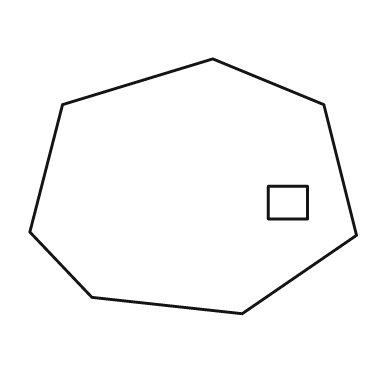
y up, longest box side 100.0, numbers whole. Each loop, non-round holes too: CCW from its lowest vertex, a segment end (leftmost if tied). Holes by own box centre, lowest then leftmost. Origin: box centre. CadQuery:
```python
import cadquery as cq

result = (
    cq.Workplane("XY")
    .moveTo(15.0, -39.0)
    .lineTo(50.0, -15.0)
    .lineTo(40.0, 25.0)
    .lineTo(6.0, 39.0)
    .lineTo(-40.0, 25.0)
    .lineTo(-50.0, -14.0)
    .lineTo(-31.0, -34.0)
    .close()
    .moveTo(23.0, -10.0)
    .lineTo(35.0, -10.0)
    .lineTo(35.0, 0.0)
    .lineTo(23.0, 0.0)
    .close()
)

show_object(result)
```